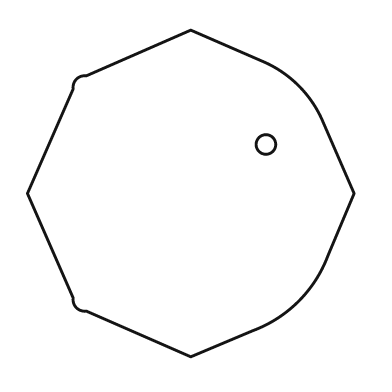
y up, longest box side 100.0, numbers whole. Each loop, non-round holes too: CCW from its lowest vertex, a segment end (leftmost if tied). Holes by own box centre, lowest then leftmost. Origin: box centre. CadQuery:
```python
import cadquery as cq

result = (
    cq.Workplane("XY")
    .moveTo(0.0, -50.0)
    .lineTo(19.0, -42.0)
    .threePointArc((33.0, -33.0), (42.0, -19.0))
    .lineTo(50.0, 0.0)
    .lineTo(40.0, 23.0)
    .threePointArc((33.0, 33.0), (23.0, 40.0))
    .lineTo(0.0, 50.0)
    .lineTo(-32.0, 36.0)
    .threePointArc((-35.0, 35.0), (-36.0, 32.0))
    .lineTo(-50.0, 0.0)
    .lineTo(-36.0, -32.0)
    .threePointArc((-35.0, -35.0), (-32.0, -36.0))
    .close()
    .moveTo(23.0, 15.0)
    .circle(3.0)
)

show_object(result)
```